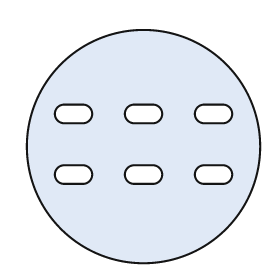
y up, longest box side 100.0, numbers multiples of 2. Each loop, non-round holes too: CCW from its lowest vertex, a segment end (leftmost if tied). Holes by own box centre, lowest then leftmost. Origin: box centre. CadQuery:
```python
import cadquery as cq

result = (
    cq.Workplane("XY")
    .moveTo(0.0, 0.0)
    .circle(50.0)
    .moveTo(-34.0, -16.0)
    .lineTo(-26.0, -16.0)
    .threePointArc((-22.0, -12.0), (-26.0, -8.0))
    .lineTo(-34.0, -8.0)
    .threePointArc((-38.0, -12.0), (-34.0, -16.0))
    .close()
    .moveTo(-4.0, -16.0)
    .lineTo(4.0, -16.0)
    .threePointArc((8.0, -12.0), (4.0, -8.0))
    .lineTo(-4.0, -8.0)
    .threePointArc((-8.0, -12.0), (-4.0, -16.0))
    .close()
    .moveTo(26.0, -16.0)
    .lineTo(34.0, -16.0)
    .threePointArc((38.0, -12.0), (34.0, -8.0))
    .lineTo(26.0, -8.0)
    .threePointArc((22.0, -12.0), (26.0, -16.0))
    .close()
    .moveTo(-34.0, 10.0)
    .lineTo(-26.0, 10.0)
    .threePointArc((-22.0, 14.0), (-26.0, 18.0))
    .lineTo(-34.0, 18.0)
    .threePointArc((-38.0, 14.0), (-34.0, 10.0))
    .close()
    .moveTo(-4.0, 10.0)
    .lineTo(4.0, 10.0)
    .threePointArc((8.0, 14.0), (4.0, 18.0))
    .lineTo(-4.0, 18.0)
    .threePointArc((-8.0, 14.0), (-4.0, 10.0))
    .close()
    .moveTo(26.0, 10.0)
    .lineTo(34.0, 10.0)
    .threePointArc((38.0, 14.0), (34.0, 18.0))
    .lineTo(26.0, 18.0)
    .threePointArc((22.0, 14.0), (26.0, 10.0))
    .close()
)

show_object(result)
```